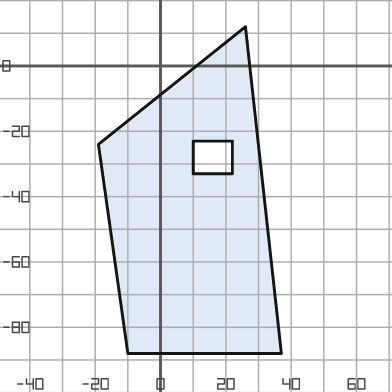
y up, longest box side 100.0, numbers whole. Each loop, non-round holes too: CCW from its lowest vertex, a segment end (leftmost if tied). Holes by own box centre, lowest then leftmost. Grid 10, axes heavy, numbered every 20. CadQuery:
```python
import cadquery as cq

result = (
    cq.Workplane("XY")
    .moveTo(-10.0, -88.0)
    .lineTo(37.0, -88.0)
    .lineTo(26.0, 12.0)
    .lineTo(-19.0, -24.0)
    .close()
    .moveTo(10.0, -33.0)
    .lineTo(22.0, -33.0)
    .lineTo(22.0, -23.0)
    .lineTo(10.0, -23.0)
    .close()
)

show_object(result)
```